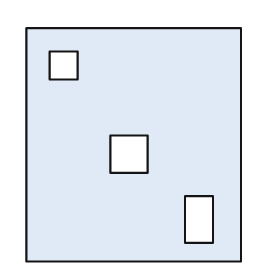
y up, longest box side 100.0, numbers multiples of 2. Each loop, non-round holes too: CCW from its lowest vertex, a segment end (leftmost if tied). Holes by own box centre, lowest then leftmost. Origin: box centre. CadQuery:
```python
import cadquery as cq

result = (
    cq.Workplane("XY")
    .moveTo(-46.0, -50.0)
    .lineTo(46.0, -50.0)
    .lineTo(46.0, 50.0)
    .lineTo(-46.0, 50.0)
    .close()
    .moveTo(22.0, -42.0)
    .lineTo(34.0, -42.0)
    .lineTo(34.0, -22.0)
    .lineTo(22.0, -22.0)
    .close()
    .moveTo(-10.0, -12.0)
    .lineTo(6.0, -12.0)
    .lineTo(6.0, 4.0)
    .lineTo(-10.0, 4.0)
    .close()
    .moveTo(-36.0, 28.0)
    .lineTo(-24.0, 28.0)
    .lineTo(-24.0, 40.0)
    .lineTo(-36.0, 40.0)
    .close()
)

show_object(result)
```